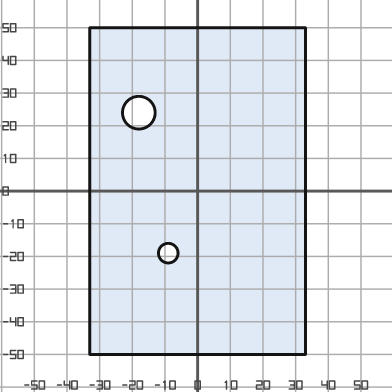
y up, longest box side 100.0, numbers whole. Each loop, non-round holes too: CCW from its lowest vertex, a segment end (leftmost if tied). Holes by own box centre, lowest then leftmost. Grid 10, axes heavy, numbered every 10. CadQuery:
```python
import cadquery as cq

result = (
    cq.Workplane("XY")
    .moveTo(-33.0, -50.0)
    .lineTo(33.0, -50.0)
    .lineTo(33.0, 50.0)
    .lineTo(-33.0, 50.0)
    .close()
    .moveTo(-9.0, -19.0)
    .circle(3.0)
    .moveTo(-18.0, 24.0)
    .circle(5.0)
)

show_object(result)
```